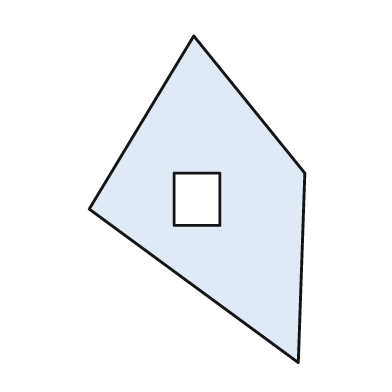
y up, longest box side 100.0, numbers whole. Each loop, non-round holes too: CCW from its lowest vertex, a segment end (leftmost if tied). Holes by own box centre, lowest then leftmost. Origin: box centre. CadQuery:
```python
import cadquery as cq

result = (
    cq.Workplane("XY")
    .moveTo(31.0, -50.0)
    .lineTo(33.0, 8.0)
    .lineTo(-1.0, 50.0)
    .lineTo(-33.0, -3.0)
    .close()
    .moveTo(-7.0, -8.0)
    .lineTo(7.0, -8.0)
    .lineTo(7.0, 8.0)
    .lineTo(-7.0, 8.0)
    .close()
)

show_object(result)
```